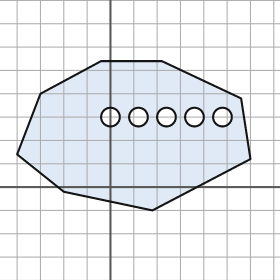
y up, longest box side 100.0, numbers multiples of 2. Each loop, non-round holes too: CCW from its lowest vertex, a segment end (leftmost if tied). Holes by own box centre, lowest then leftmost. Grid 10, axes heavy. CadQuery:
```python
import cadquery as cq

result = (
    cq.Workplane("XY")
    .moveTo(18.0, -10.0)
    .lineTo(60.0, 12.0)
    .lineTo(56.0, 38.0)
    .lineTo(22.0, 54.0)
    .lineTo(-4.0, 54.0)
    .lineTo(-30.0, 40.0)
    .lineTo(-40.0, 14.0)
    .lineTo(-20.0, -2.0)
    .close()
    .moveTo(0.0, 30.0)
    .circle(4.0)
    .moveTo(12.0, 30.0)
    .circle(4.0)
    .moveTo(24.0, 30.0)
    .circle(4.0)
    .moveTo(36.0, 30.0)
    .circle(4.0)
    .moveTo(48.0, 30.0)
    .circle(4.0)
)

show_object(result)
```